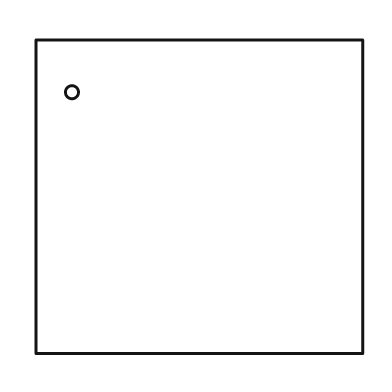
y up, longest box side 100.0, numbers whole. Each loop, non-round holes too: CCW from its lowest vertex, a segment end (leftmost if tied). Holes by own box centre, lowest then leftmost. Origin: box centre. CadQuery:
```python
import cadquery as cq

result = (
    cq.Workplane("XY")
    .moveTo(-50.0, -48.0)
    .lineTo(50.0, -48.0)
    .lineTo(50.0, 48.0)
    .lineTo(-50.0, 48.0)
    .close()
    .moveTo(-39.0, 32.0)
    .circle(2.0)
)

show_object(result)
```